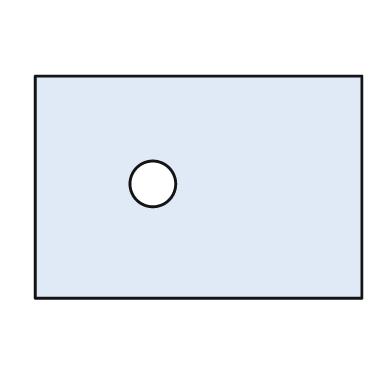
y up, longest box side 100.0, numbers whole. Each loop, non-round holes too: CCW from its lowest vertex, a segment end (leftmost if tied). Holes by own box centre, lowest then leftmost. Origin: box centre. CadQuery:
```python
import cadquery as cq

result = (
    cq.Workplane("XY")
    .moveTo(-50.0, -34.0)
    .lineTo(50.0, -34.0)
    .lineTo(50.0, 34.0)
    .lineTo(-50.0, 34.0)
    .close()
    .moveTo(-14.0, 1.0)
    .circle(7.0)
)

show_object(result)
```